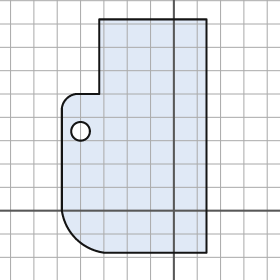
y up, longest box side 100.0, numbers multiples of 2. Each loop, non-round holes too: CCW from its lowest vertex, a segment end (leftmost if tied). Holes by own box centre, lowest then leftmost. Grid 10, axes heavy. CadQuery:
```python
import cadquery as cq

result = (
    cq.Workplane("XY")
    .moveTo(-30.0, -18.0)
    .lineTo(14.0, -18.0)
    .lineTo(14.0, 82.0)
    .lineTo(-32.0, 82.0)
    .lineTo(-32.0, 50.0)
    .lineTo(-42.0, 50.0)
    .threePointArc((-46.0, 48.0), (-48.0, 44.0))
    .lineTo(-48.0, 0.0)
    .threePointArc((-42.0, -12.0), (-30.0, -18.0))
    .close()
    .moveTo(-40.0, 34.0)
    .circle(4.0)
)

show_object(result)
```